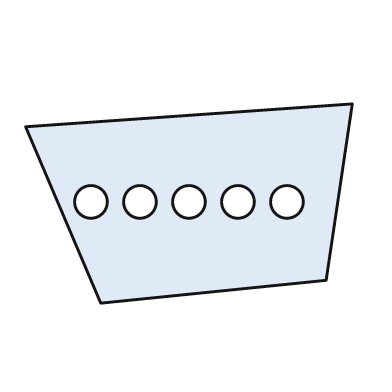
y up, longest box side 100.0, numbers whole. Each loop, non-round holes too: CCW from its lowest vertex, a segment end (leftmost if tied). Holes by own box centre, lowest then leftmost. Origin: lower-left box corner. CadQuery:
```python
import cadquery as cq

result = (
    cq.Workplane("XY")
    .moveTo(23.0, 0.0)
    .lineTo(92.0, 7.0)
    .lineTo(100.0, 61.0)
    .lineTo(0.0, 54.0)
    .close()
    .moveTo(20.0, 31.0)
    .circle(5.0)
    .moveTo(35.0, 31.0)
    .circle(5.0)
    .moveTo(50.0, 31.0)
    .circle(5.0)
    .moveTo(65.0, 31.0)
    .circle(5.0)
    .moveTo(80.0, 31.0)
    .circle(5.0)
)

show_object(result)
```